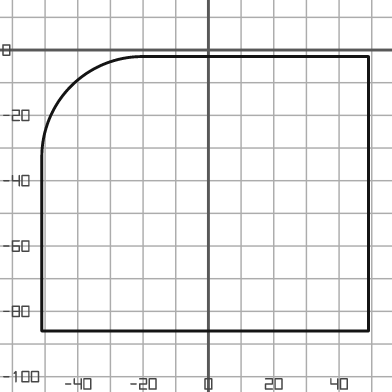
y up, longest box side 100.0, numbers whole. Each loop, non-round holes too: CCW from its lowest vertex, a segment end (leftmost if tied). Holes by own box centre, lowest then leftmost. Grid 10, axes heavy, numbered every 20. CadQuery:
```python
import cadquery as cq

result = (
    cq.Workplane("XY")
    .moveTo(-51.0, -86.0)
    .lineTo(49.0, -86.0)
    .lineTo(49.0, -2.0)
    .lineTo(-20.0, -2.0)
    .threePointArc((-42.0, -11.0), (-51.0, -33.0))
    .close()
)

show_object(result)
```